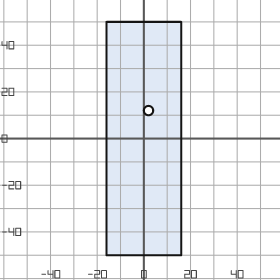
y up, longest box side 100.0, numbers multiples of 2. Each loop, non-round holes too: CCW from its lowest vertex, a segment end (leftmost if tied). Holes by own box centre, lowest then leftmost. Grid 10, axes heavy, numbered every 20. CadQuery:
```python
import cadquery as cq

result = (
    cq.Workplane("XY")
    .moveTo(-16.0, -50.0)
    .lineTo(16.0, -50.0)
    .lineTo(16.0, 50.0)
    .lineTo(-16.0, 50.0)
    .close()
    .moveTo(2.0, 12.0)
    .circle(2.0)
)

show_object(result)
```